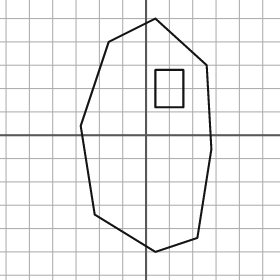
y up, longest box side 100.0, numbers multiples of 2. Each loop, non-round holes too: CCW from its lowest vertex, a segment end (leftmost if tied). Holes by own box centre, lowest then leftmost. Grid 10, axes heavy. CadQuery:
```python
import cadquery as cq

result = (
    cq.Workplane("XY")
    .moveTo(4.0, -50.0)
    .lineTo(22.0, -44.0)
    .lineTo(28.0, -6.0)
    .lineTo(26.0, 30.0)
    .lineTo(4.0, 50.0)
    .lineTo(-16.0, 40.0)
    .lineTo(-28.0, 4.0)
    .lineTo(-22.0, -34.0)
    .close()
    .moveTo(4.0, 12.0)
    .lineTo(16.0, 12.0)
    .lineTo(16.0, 28.0)
    .lineTo(4.0, 28.0)
    .close()
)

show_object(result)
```